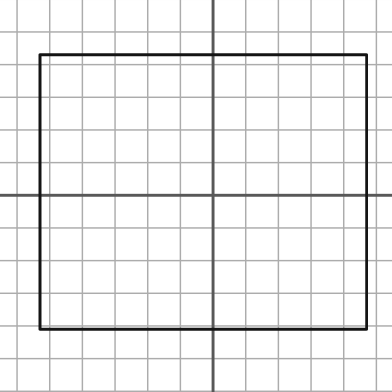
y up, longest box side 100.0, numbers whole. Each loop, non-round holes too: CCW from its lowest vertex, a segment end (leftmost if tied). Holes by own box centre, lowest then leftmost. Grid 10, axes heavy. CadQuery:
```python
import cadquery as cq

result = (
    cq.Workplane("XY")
    .moveTo(-53.0, -41.0)
    .lineTo(47.0, -41.0)
    .lineTo(47.0, 43.0)
    .lineTo(-53.0, 43.0)
    .close()
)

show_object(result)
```